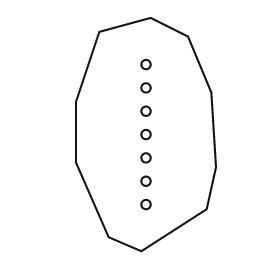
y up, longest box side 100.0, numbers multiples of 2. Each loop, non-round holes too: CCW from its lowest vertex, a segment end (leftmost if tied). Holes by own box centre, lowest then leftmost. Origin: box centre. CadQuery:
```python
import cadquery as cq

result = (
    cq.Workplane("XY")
    .moveTo(-2.0, -50.0)
    .lineTo(26.0, -32.0)
    .lineTo(30.0, -14.0)
    .lineTo(28.0, 18.0)
    .lineTo(18.0, 42.0)
    .lineTo(2.0, 50.0)
    .lineTo(-20.0, 44.0)
    .lineTo(-30.0, 14.0)
    .lineTo(-30.0, -12.0)
    .lineTo(-16.0, -44.0)
    .close()
    .moveTo(0.0, -30.0)
    .circle(2.0)
    .moveTo(0.0, -20.0)
    .circle(2.0)
    .moveTo(0.0, -10.0)
    .circle(2.0)
    .moveTo(0.0, 0.0)
    .circle(2.0)
    .moveTo(0.0, 10.0)
    .circle(2.0)
    .moveTo(0.0, 20.0)
    .circle(2.0)
    .moveTo(0.0, 30.0)
    .circle(2.0)
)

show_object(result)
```